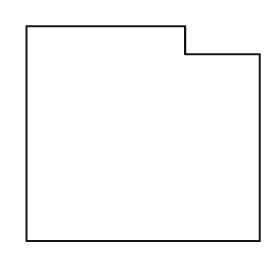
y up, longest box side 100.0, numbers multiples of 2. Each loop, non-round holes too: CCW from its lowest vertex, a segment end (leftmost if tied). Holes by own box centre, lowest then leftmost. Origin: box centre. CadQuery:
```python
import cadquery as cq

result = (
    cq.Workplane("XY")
    .moveTo(-50.0, -46.0)
    .lineTo(50.0, -46.0)
    .lineTo(50.0, 34.0)
    .lineTo(18.0, 34.0)
    .lineTo(18.0, 46.0)
    .lineTo(-50.0, 46.0)
    .close()
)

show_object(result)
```